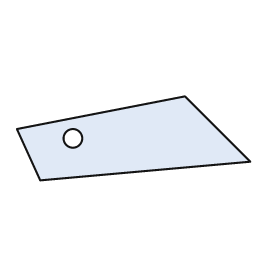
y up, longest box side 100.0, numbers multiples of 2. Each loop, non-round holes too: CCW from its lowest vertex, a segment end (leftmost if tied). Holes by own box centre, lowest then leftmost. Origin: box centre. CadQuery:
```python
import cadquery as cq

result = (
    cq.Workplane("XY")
    .moveTo(-40.0, -18.0)
    .lineTo(50.0, -10.0)
    .lineTo(22.0, 18.0)
    .lineTo(-50.0, 4.0)
    .close()
    .moveTo(-26.0, 0.0)
    .circle(4.0)
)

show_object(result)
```